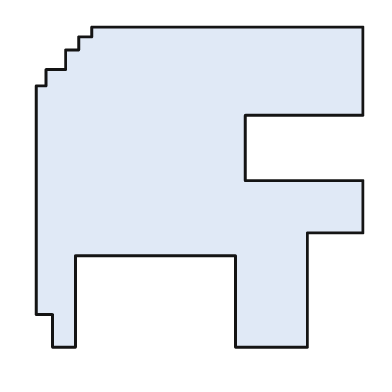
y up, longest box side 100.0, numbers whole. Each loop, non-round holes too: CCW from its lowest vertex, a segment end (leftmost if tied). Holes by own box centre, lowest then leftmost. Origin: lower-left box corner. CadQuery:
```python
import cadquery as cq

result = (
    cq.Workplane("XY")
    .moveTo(5.0, 0.0)
    .lineTo(12.0, 0.0)
    .lineTo(12.0, 28.0)
    .lineTo(61.0, 28.0)
    .lineTo(61.0, 0.0)
    .lineTo(83.0, 0.0)
    .lineTo(83.0, 35.0)
    .lineTo(100.0, 35.0)
    .lineTo(100.0, 51.0)
    .lineTo(64.0, 51.0)
    .lineTo(64.0, 71.0)
    .lineTo(100.0, 71.0)
    .lineTo(100.0, 98.0)
    .lineTo(17.0, 98.0)
    .lineTo(17.0, 95.0)
    .lineTo(13.0, 95.0)
    .lineTo(13.0, 91.0)
    .lineTo(9.0, 91.0)
    .lineTo(9.0, 85.0)
    .lineTo(3.0, 85.0)
    .lineTo(3.0, 80.0)
    .lineTo(0.0, 80.0)
    .lineTo(0.0, 10.0)
    .lineTo(5.0, 10.0)
    .close()
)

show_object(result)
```